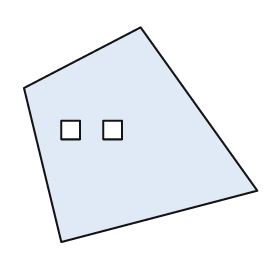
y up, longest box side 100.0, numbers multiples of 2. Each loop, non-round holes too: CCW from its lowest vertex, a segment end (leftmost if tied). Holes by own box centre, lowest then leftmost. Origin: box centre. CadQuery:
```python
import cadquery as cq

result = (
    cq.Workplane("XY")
    .moveTo(-34.0, -46.0)
    .lineTo(50.0, -24.0)
    .lineTo(0.0, 46.0)
    .lineTo(-50.0, 20.0)
    .close()
    .moveTo(-34.0, -2.0)
    .lineTo(-26.0, -2.0)
    .lineTo(-26.0, 6.0)
    .lineTo(-34.0, 6.0)
    .close()
    .moveTo(-16.0, -2.0)
    .lineTo(-8.0, -2.0)
    .lineTo(-8.0, 6.0)
    .lineTo(-16.0, 6.0)
    .close()
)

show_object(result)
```